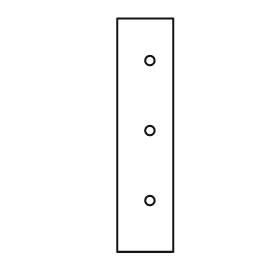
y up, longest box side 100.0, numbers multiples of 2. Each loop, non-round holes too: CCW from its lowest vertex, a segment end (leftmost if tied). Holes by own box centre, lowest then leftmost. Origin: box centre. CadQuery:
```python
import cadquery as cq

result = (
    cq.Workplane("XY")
    .moveTo(-12.0, -50.0)
    .lineTo(12.0, -50.0)
    .lineTo(12.0, 50.0)
    .lineTo(-12.0, 50.0)
    .close()
    .moveTo(2.0, -28.0)
    .circle(2.0)
    .moveTo(2.0, 2.0)
    .circle(2.0)
    .moveTo(2.0, 32.0)
    .circle(2.0)
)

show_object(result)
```